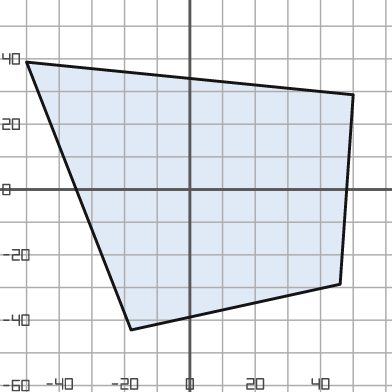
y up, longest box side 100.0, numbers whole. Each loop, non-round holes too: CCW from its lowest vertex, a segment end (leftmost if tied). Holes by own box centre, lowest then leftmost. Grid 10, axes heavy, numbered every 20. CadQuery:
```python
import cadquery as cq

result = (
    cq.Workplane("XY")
    .moveTo(-18.0, -43.0)
    .lineTo(46.0, -29.0)
    .lineTo(50.0, 29.0)
    .lineTo(-50.0, 39.0)
    .close()
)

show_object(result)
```